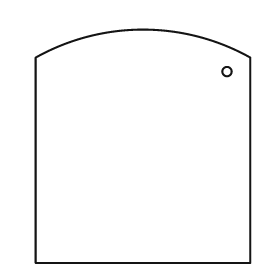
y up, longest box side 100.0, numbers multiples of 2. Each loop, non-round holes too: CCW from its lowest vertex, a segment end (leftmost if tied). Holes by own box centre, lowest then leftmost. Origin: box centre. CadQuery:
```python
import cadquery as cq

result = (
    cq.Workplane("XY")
    .moveTo(-46.0, -50.0)
    .lineTo(46.0, -50.0)
    .lineTo(46.0, 38.0)
    .threePointArc((0.0, 50.0), (-46.0, 38.0))
    .close()
    .moveTo(36.0, 32.0)
    .circle(2.0)
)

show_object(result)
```